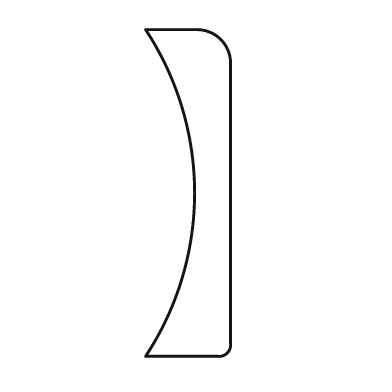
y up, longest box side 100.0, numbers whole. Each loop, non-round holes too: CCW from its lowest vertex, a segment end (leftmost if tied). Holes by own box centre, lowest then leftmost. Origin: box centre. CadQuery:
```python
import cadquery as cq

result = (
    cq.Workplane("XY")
    .moveTo(-13.0, -50.0)
    .lineTo(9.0, -50.0)
    .threePointArc((12.0, -49.0), (13.0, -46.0))
    .lineTo(13.0, 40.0)
    .threePointArc((10.0, 47.0), (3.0, 50.0))
    .lineTo(-13.0, 50.0)
    .threePointArc((2.0, 0.0), (-13.0, -50.0))
    .close()
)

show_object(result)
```